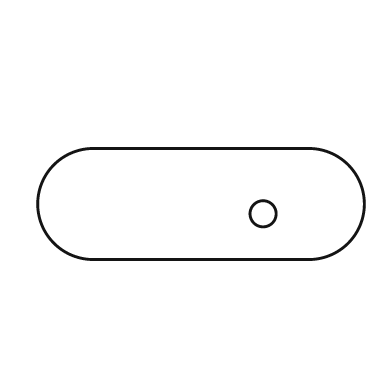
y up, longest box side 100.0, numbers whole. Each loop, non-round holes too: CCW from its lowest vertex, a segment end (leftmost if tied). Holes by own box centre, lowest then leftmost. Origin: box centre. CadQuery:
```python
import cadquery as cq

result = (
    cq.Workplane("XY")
    .moveTo(-33.0, -17.0)
    .lineTo(33.0, -17.0)
    .threePointArc((50.0, 0.0), (33.0, 17.0))
    .lineTo(-33.0, 17.0)
    .threePointArc((-50.0, 0.0), (-33.0, -17.0))
    .close()
    .moveTo(19.0, -3.0)
    .circle(4.0)
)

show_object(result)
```